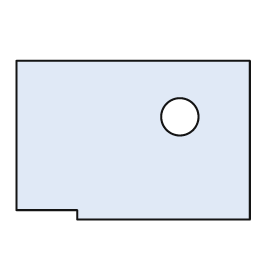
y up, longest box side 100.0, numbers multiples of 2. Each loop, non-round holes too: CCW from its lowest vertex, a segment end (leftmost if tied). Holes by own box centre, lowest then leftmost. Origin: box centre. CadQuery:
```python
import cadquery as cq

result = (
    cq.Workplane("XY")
    .moveTo(-24.0, -34.0)
    .lineTo(50.0, -34.0)
    .lineTo(50.0, 34.0)
    .lineTo(-50.0, 34.0)
    .lineTo(-50.0, -30.0)
    .lineTo(-24.0, -30.0)
    .close()
    .moveTo(20.0, 10.0)
    .circle(8.0)
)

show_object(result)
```